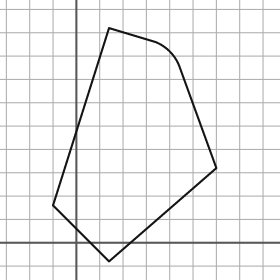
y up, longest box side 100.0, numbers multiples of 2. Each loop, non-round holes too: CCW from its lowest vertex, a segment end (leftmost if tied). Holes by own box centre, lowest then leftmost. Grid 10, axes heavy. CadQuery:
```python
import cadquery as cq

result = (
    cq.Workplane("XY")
    .moveTo(14.0, -8.0)
    .lineTo(60.0, 32.0)
    .lineTo(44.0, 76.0)
    .threePointArc((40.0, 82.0), (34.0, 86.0))
    .lineTo(14.0, 92.0)
    .lineTo(-10.0, 16.0)
    .close()
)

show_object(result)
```